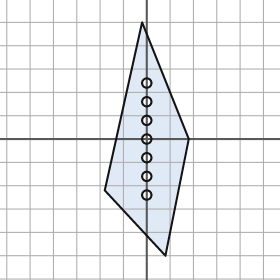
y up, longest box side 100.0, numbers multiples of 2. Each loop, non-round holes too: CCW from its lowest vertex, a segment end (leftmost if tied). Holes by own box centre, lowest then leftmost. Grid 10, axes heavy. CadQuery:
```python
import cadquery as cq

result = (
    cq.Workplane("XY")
    .moveTo(8.0, -50.0)
    .lineTo(18.0, 0.0)
    .lineTo(-2.0, 50.0)
    .lineTo(-18.0, -22.0)
    .close()
    .moveTo(0.0, -24.0)
    .circle(2.0)
    .moveTo(0.0, -16.0)
    .circle(2.0)
    .moveTo(0.0, -8.0)
    .circle(2.0)
    .moveTo(0.0, 0.0)
    .circle(2.0)
    .moveTo(0.0, 8.0)
    .circle(2.0)
    .moveTo(0.0, 16.0)
    .circle(2.0)
    .moveTo(0.0, 24.0)
    .circle(2.0)
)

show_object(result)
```